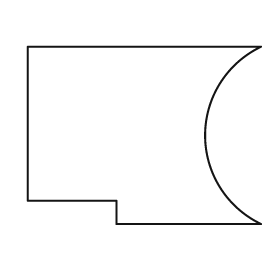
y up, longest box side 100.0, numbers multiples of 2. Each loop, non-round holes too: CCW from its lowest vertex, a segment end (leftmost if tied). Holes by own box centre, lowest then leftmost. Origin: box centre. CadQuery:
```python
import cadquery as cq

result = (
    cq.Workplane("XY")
    .moveTo(-12.0, -38.0)
    .lineTo(50.0, -38.0)
    .threePointArc((26.0, 0.0), (50.0, 38.0))
    .lineTo(-50.0, 38.0)
    .lineTo(-50.0, -28.0)
    .lineTo(-12.0, -28.0)
    .close()
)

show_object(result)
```